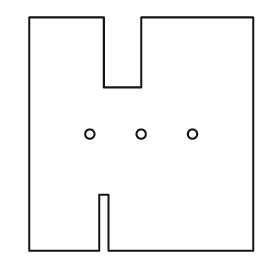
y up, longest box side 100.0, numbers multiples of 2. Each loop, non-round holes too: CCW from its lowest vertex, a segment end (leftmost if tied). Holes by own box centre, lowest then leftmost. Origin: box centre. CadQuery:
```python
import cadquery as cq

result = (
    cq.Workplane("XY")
    .moveTo(-48.0, -50.0)
    .lineTo(-18.0, -50.0)
    .lineTo(-18.0, -26.0)
    .lineTo(-14.0, -26.0)
    .lineTo(-14.0, -50.0)
    .lineTo(48.0, -50.0)
    .lineTo(48.0, 50.0)
    .lineTo(0.0, 50.0)
    .lineTo(0.0, 20.0)
    .lineTo(-16.0, 20.0)
    .lineTo(-16.0, 50.0)
    .lineTo(-48.0, 50.0)
    .close()
    .moveTo(-22.0, 0.0)
    .circle(2.0)
    .moveTo(0.0, 0.0)
    .circle(2.0)
    .moveTo(22.0, 0.0)
    .circle(2.0)
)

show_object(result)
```